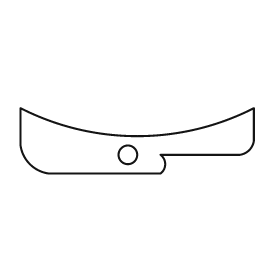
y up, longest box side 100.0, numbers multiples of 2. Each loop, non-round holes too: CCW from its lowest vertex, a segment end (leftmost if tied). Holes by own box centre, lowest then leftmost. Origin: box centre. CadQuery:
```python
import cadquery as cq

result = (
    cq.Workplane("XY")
    .moveTo(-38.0, -14.0)
    .lineTo(10.0, -14.0)
    .threePointArc((12.0, -10.0), (10.0, -6.0))
    .lineTo(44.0, -6.0)
    .threePointArc((48.0, -4.0), (50.0, 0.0))
    .lineTo(50.0, 14.0)
    .threePointArc((0.0, 2.0), (-50.0, 14.0))
    .lineTo(-50.0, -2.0)
    .threePointArc((-46.0, -10.0), (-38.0, -14.0))
    .close()
    .moveTo(-4.0, -6.0)
    .circle(4.0)
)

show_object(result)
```